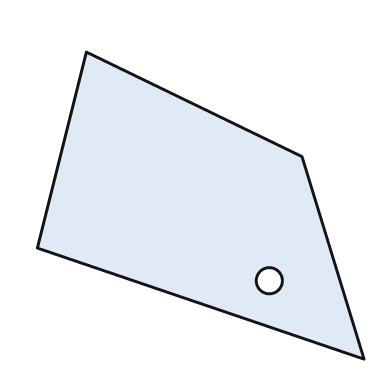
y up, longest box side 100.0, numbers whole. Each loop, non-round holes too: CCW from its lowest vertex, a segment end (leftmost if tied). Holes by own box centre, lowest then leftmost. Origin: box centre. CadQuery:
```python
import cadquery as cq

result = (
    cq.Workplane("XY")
    .moveTo(50.0, -47.0)
    .lineTo(31.0, 15.0)
    .lineTo(-35.0, 47.0)
    .lineTo(-50.0, -13.0)
    .close()
    .moveTo(21.0, -23.0)
    .circle(4.0)
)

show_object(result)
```